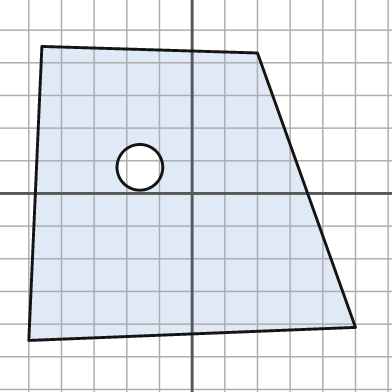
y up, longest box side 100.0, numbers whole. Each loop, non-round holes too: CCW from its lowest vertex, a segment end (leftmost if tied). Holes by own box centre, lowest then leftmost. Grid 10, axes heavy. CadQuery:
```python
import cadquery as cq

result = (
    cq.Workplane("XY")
    .moveTo(-50.0, -45.0)
    .lineTo(50.0, -41.0)
    .lineTo(20.0, 43.0)
    .lineTo(-46.0, 45.0)
    .close()
    .moveTo(-16.0, 8.0)
    .circle(7.0)
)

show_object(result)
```